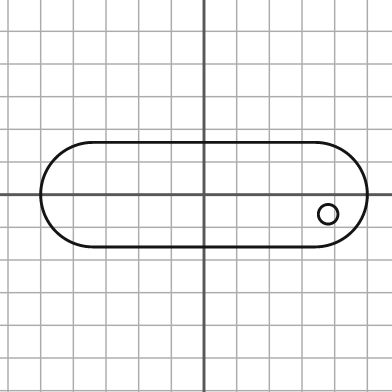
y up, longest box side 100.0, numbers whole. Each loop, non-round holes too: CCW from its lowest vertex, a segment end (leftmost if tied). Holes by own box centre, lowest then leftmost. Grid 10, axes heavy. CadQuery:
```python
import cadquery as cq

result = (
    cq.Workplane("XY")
    .moveTo(-34.0, -16.0)
    .lineTo(34.0, -16.0)
    .threePointArc((50.0, 0.0), (34.0, 16.0))
    .lineTo(-34.0, 16.0)
    .threePointArc((-50.0, 0.0), (-34.0, -16.0))
    .close()
    .moveTo(38.0, -6.0)
    .circle(3.0)
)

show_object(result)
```